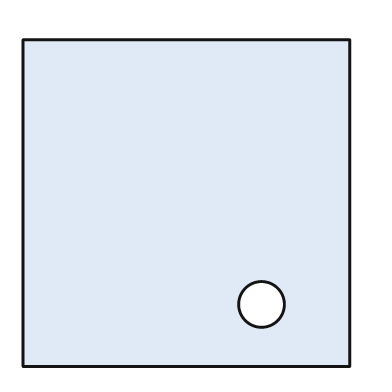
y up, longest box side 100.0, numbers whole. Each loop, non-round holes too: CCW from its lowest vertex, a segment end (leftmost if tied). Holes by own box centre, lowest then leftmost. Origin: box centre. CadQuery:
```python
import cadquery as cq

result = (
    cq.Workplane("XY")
    .moveTo(-50.0, -50.0)
    .lineTo(50.0, -50.0)
    .lineTo(50.0, 50.0)
    .lineTo(-50.0, 50.0)
    .close()
    .moveTo(23.0, -31.0)
    .circle(7.0)
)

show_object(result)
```